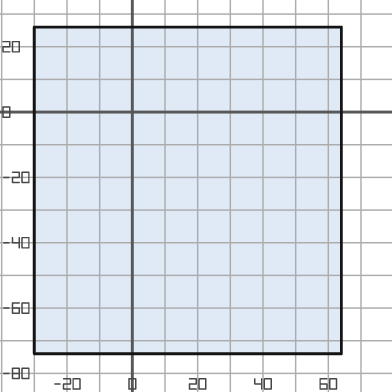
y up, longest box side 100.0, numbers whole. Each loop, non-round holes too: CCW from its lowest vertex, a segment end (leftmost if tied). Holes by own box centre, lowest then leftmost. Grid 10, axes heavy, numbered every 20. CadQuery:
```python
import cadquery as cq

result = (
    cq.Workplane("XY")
    .moveTo(-30.0, -74.0)
    .lineTo(64.0, -74.0)
    .lineTo(64.0, 26.0)
    .lineTo(-30.0, 26.0)
    .close()
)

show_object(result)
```